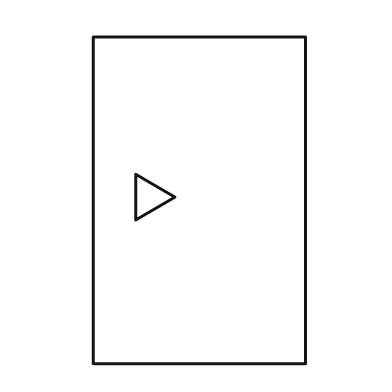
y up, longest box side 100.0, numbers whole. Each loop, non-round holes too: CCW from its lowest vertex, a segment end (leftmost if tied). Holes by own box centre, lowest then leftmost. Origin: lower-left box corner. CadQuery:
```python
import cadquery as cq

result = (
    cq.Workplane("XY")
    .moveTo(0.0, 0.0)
    .lineTo(65.0, 0.0)
    .lineTo(65.0, 100.0)
    .lineTo(0.0, 100.0)
    .close()
    .moveTo(13.0, 44.0)
    .lineTo(25.0, 51.0)
    .lineTo(13.0, 58.0)
    .close()
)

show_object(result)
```